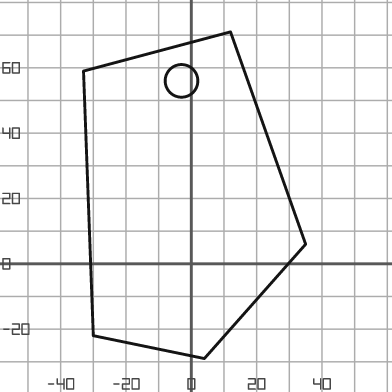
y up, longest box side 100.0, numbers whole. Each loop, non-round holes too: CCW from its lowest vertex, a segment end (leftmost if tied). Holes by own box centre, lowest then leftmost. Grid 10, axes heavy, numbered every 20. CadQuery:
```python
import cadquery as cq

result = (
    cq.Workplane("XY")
    .moveTo(4.0, -29.0)
    .lineTo(35.0, 6.0)
    .lineTo(12.0, 71.0)
    .lineTo(-33.0, 59.0)
    .lineTo(-30.0, -22.0)
    .close()
    .moveTo(-3.0, 56.0)
    .circle(5.0)
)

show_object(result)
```